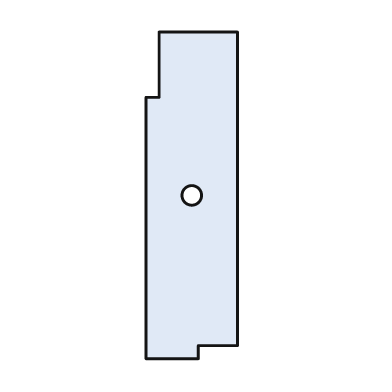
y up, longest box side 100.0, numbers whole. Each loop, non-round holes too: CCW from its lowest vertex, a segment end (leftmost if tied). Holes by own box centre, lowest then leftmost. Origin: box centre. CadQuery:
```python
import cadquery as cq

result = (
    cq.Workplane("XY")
    .moveTo(-14.0, -50.0)
    .lineTo(2.0, -50.0)
    .lineTo(2.0, -46.0)
    .lineTo(14.0, -46.0)
    .lineTo(14.0, 50.0)
    .lineTo(-10.0, 50.0)
    .lineTo(-10.0, 30.0)
    .lineTo(-14.0, 30.0)
    .close()
    .moveTo(0.0, 0.0)
    .circle(3.0)
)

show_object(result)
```